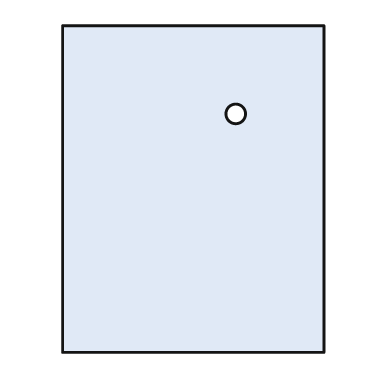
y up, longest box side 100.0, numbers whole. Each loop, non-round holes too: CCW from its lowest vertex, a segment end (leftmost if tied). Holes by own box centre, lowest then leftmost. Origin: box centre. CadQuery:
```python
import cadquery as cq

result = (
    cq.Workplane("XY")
    .moveTo(-40.0, -50.0)
    .lineTo(40.0, -50.0)
    .lineTo(40.0, 50.0)
    .lineTo(-40.0, 50.0)
    .close()
    .moveTo(13.0, 23.0)
    .circle(3.0)
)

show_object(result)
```